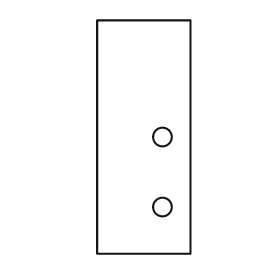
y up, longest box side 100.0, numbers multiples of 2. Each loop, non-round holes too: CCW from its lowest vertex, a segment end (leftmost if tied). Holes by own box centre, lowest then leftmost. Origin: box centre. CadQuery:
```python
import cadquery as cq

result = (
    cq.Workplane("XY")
    .moveTo(-20.0, -50.0)
    .lineTo(20.0, -50.0)
    .lineTo(20.0, 50.0)
    .lineTo(-20.0, 50.0)
    .close()
    .moveTo(8.0, -30.0)
    .circle(4.0)
    .moveTo(8.0, 0.0)
    .circle(4.0)
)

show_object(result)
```